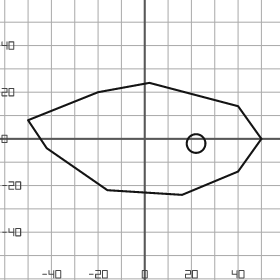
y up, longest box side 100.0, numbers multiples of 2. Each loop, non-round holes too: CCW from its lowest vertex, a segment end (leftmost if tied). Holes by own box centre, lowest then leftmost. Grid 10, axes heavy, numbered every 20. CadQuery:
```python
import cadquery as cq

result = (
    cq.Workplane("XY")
    .moveTo(16.0, -24.0)
    .lineTo(40.0, -14.0)
    .lineTo(50.0, 0.0)
    .lineTo(40.0, 14.0)
    .lineTo(2.0, 24.0)
    .lineTo(-20.0, 20.0)
    .lineTo(-50.0, 8.0)
    .lineTo(-42.0, -4.0)
    .lineTo(-16.0, -22.0)
    .close()
    .moveTo(22.0, -2.0)
    .circle(4.0)
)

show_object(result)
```